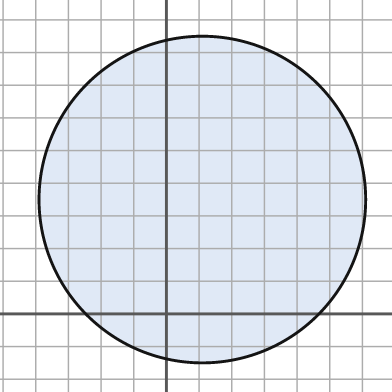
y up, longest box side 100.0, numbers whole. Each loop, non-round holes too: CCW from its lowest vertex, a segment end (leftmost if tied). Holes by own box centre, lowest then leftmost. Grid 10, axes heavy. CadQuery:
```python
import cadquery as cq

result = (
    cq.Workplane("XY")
    .moveTo(11.0, 35.0)
    .circle(50.0)
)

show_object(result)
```